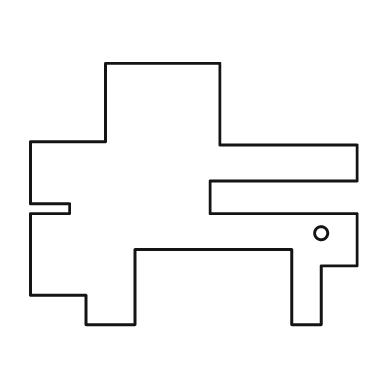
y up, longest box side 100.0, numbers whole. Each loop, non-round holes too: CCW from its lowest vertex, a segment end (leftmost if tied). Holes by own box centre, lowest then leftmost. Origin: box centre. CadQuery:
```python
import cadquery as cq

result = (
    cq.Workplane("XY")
    .moveTo(-33.0, -40.0)
    .lineTo(-18.0, -40.0)
    .lineTo(-18.0, -17.0)
    .lineTo(30.0, -17.0)
    .lineTo(30.0, -40.0)
    .lineTo(39.0, -40.0)
    .lineTo(39.0, -22.0)
    .lineTo(50.0, -22.0)
    .lineTo(50.0, -6.0)
    .lineTo(5.0, -6.0)
    .lineTo(5.0, 4.0)
    .lineTo(50.0, 4.0)
    .lineTo(50.0, 15.0)
    .lineTo(8.0, 15.0)
    .lineTo(8.0, 40.0)
    .lineTo(-27.0, 40.0)
    .lineTo(-27.0, 16.0)
    .lineTo(-50.0, 16.0)
    .lineTo(-50.0, -3.0)
    .lineTo(-38.0, -3.0)
    .lineTo(-38.0, -6.0)
    .lineTo(-50.0, -6.0)
    .lineTo(-50.0, -31.0)
    .lineTo(-33.0, -31.0)
    .close()
    .moveTo(39.0, -12.0)
    .circle(2.0)
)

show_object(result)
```